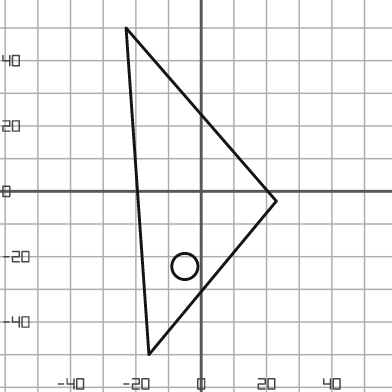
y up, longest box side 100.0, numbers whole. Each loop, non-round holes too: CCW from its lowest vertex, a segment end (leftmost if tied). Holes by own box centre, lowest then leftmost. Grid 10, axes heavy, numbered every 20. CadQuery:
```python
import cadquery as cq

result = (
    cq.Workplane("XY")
    .moveTo(-16.0, -50.0)
    .lineTo(23.0, -3.0)
    .lineTo(-23.0, 50.0)
    .close()
    .moveTo(-5.0, -23.0)
    .circle(4.0)
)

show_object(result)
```